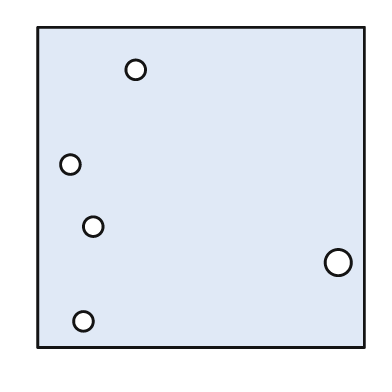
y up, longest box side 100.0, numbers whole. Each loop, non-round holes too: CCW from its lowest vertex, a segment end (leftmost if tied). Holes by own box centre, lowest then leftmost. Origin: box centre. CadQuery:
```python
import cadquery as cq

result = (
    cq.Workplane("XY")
    .moveTo(-50.0, -49.0)
    .lineTo(50.0, -49.0)
    .lineTo(50.0, 49.0)
    .lineTo(-50.0, 49.0)
    .close()
    .moveTo(-36.0, -41.0)
    .circle(3.0)
    .moveTo(42.0, -23.0)
    .circle(4.0)
    .moveTo(-33.0, -12.0)
    .circle(3.0)
    .moveTo(-40.0, 7.0)
    .circle(3.0)
    .moveTo(-20.0, 36.0)
    .circle(3.0)
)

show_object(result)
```